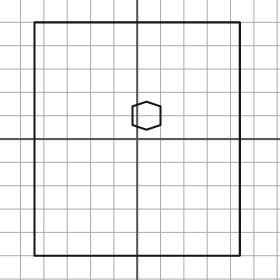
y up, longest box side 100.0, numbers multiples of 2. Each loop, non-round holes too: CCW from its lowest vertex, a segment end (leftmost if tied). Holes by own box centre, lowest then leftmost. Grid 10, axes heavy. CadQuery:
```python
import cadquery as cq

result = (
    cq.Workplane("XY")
    .moveTo(-44.0, -50.0)
    .lineTo(44.0, -50.0)
    .lineTo(44.0, 50.0)
    .lineTo(-44.0, 50.0)
    .close()
    .moveTo(4.0, 4.0)
    .lineTo(10.0, 6.0)
    .lineTo(10.0, 14.0)
    .lineTo(4.0, 16.0)
    .lineTo(-2.0, 14.0)
    .lineTo(-2.0, 6.0)
    .close()
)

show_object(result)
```